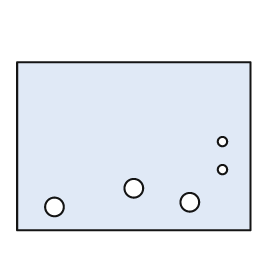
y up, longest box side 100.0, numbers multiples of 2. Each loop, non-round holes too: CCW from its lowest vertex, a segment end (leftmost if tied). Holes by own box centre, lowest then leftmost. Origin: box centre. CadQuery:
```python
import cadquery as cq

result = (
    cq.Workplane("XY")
    .moveTo(-50.0, -36.0)
    .lineTo(50.0, -36.0)
    .lineTo(50.0, 36.0)
    .lineTo(-50.0, 36.0)
    .close()
    .moveTo(-34.0, -26.0)
    .circle(4.0)
    .moveTo(24.0, -24.0)
    .circle(4.0)
    .moveTo(0.0, -18.0)
    .circle(4.0)
    .moveTo(38.0, -10.0)
    .circle(2.0)
    .moveTo(38.0, 2.0)
    .circle(2.0)
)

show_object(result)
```